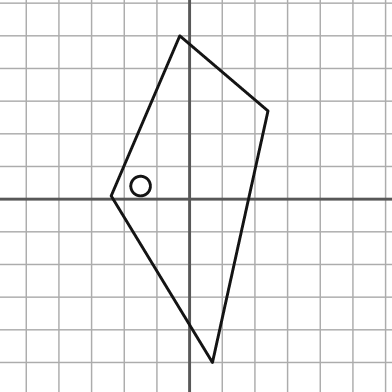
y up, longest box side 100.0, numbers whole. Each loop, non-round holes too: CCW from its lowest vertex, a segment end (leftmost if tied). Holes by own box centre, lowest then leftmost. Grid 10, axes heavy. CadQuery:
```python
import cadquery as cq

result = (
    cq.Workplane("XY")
    .moveTo(7.0, -50.0)
    .lineTo(24.0, 27.0)
    .lineTo(-3.0, 50.0)
    .lineTo(-24.0, 1.0)
    .close()
    .moveTo(-15.0, 4.0)
    .circle(3.0)
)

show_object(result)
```